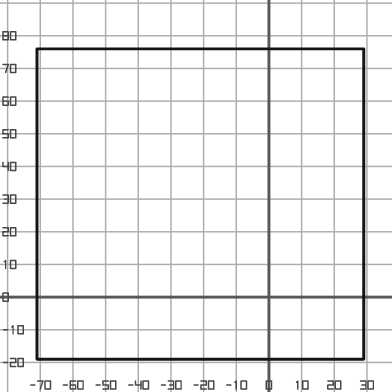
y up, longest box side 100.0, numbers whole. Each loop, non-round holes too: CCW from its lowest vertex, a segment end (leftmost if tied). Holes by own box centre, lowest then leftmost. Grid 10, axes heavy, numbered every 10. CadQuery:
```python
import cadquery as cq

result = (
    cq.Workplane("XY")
    .moveTo(-71.0, -19.0)
    .lineTo(29.0, -19.0)
    .lineTo(29.0, 76.0)
    .lineTo(-71.0, 76.0)
    .close()
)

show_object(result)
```